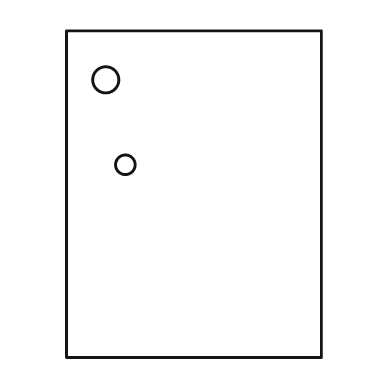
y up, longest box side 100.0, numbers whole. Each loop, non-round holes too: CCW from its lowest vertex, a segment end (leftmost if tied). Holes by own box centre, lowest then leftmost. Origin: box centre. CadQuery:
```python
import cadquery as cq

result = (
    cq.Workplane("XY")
    .moveTo(-39.0, -50.0)
    .lineTo(39.0, -50.0)
    .lineTo(39.0, 50.0)
    .lineTo(-39.0, 50.0)
    .close()
    .moveTo(-21.0, 9.0)
    .circle(3.0)
    .moveTo(-27.0, 35.0)
    .circle(4.0)
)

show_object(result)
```